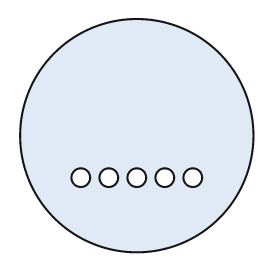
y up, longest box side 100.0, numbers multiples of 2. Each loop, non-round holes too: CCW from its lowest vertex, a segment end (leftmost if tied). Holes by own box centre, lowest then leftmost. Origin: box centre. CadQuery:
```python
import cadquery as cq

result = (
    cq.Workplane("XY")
    .moveTo(0.0, 0.0)
    .circle(50.0)
    .moveTo(-24.0, -18.0)
    .circle(4.0)
    .moveTo(-12.0, -18.0)
    .circle(4.0)
    .moveTo(0.0, -18.0)
    .circle(4.0)
    .moveTo(12.0, -18.0)
    .circle(4.0)
    .moveTo(24.0, -18.0)
    .circle(4.0)
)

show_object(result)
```